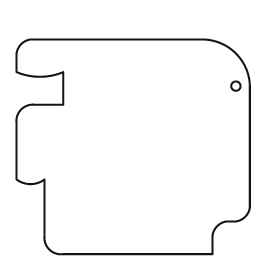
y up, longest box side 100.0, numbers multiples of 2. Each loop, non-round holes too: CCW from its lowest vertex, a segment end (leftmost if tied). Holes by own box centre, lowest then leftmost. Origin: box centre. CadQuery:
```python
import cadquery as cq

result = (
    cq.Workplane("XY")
    .moveTo(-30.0, -46.0)
    .lineTo(34.0, -46.0)
    .lineTo(34.0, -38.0)
    .threePointArc((36.0, -34.0), (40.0, -32.0))
    .lineTo(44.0, -32.0)
    .threePointArc((48.0, -30.0), (50.0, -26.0))
    .lineTo(50.0, 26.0)
    .threePointArc((44.0, 40.0), (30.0, 46.0))
    .lineTo(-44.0, 46.0)
    .threePointArc((-48.0, 44.0), (-50.0, 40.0))
    .lineTo(-50.0, 32.0)
    .threePointArc((-40.0, 30.0), (-30.0, 32.0))
    .lineTo(-30.0, 18.0)
    .lineTo(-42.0, 18.0)
    .threePointArc((-48.0, 16.0), (-50.0, 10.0))
    .lineTo(-50.0, -14.0)
    .threePointArc((-44.0, -16.0), (-38.0, -14.0))
    .lineTo(-38.0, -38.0)
    .threePointArc((-36.0, -44.0), (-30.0, -46.0))
    .close()
    .moveTo(44.0, 26.0)
    .circle(2.0)
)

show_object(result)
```